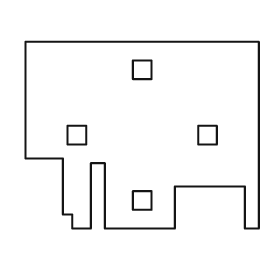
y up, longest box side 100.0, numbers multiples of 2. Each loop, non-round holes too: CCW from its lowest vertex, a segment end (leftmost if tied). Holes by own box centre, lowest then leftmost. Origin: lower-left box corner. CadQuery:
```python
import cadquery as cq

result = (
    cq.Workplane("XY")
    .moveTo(20.0, 0.0)
    .lineTo(28.0, 0.0)
    .lineTo(28.0, 28.0)
    .lineTo(34.0, 28.0)
    .lineTo(34.0, 0.0)
    .lineTo(64.0, 0.0)
    .lineTo(64.0, 18.0)
    .lineTo(94.0, 18.0)
    .lineTo(94.0, 0.0)
    .lineTo(100.0, 0.0)
    .lineTo(100.0, 80.0)
    .lineTo(0.0, 80.0)
    .lineTo(0.0, 30.0)
    .lineTo(16.0, 30.0)
    .lineTo(16.0, 6.0)
    .lineTo(20.0, 6.0)
    .close()
    .moveTo(46.0, 8.0)
    .lineTo(54.0, 8.0)
    .lineTo(54.0, 16.0)
    .lineTo(46.0, 16.0)
    .close()
    .moveTo(18.0, 36.0)
    .lineTo(26.0, 36.0)
    .lineTo(26.0, 44.0)
    .lineTo(18.0, 44.0)
    .close()
    .moveTo(74.0, 36.0)
    .lineTo(82.0, 36.0)
    .lineTo(82.0, 44.0)
    .lineTo(74.0, 44.0)
    .close()
    .moveTo(46.0, 64.0)
    .lineTo(54.0, 64.0)
    .lineTo(54.0, 72.0)
    .lineTo(46.0, 72.0)
    .close()
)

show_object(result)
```